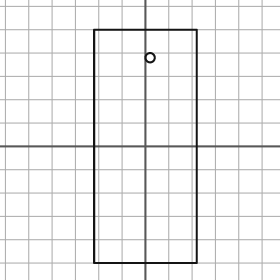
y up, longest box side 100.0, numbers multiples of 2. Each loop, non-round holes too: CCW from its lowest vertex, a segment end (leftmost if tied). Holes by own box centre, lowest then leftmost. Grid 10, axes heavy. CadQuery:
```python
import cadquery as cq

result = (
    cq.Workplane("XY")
    .moveTo(-22.0, -50.0)
    .lineTo(22.0, -50.0)
    .lineTo(22.0, 50.0)
    .lineTo(-22.0, 50.0)
    .close()
    .moveTo(2.0, 38.0)
    .circle(2.0)
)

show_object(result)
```